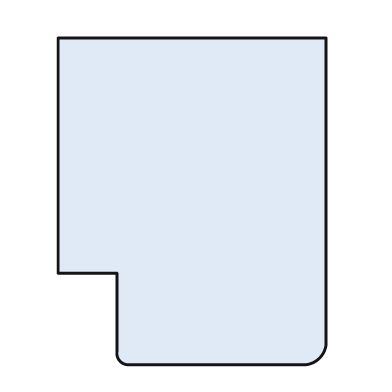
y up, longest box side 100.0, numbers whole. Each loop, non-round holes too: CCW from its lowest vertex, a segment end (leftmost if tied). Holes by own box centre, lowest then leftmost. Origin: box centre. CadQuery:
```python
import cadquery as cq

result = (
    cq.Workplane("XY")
    .moveTo(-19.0, -50.0)
    .lineTo(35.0, -50.0)
    .threePointArc((39.0, -48.0), (41.0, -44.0))
    .lineTo(41.0, 50.0)
    .lineTo(-41.0, 50.0)
    .lineTo(-41.0, -22.0)
    .lineTo(-23.0, -22.0)
    .lineTo(-23.0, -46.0)
    .threePointArc((-22.0, -49.0), (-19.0, -50.0))
    .close()
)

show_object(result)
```